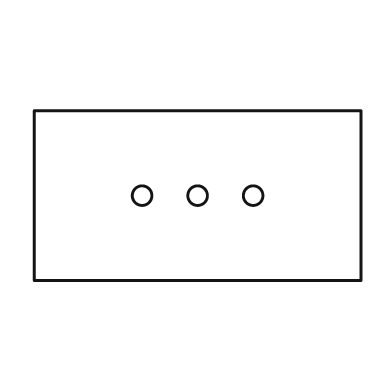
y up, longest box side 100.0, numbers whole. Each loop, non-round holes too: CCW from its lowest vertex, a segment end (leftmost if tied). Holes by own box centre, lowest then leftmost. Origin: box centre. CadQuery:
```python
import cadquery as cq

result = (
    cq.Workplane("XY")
    .moveTo(-50.0, -26.0)
    .lineTo(50.0, -26.0)
    .lineTo(50.0, 26.0)
    .lineTo(-50.0, 26.0)
    .close()
    .moveTo(-17.0, 0.0)
    .circle(3.0)
    .moveTo(0.0, 0.0)
    .circle(3.0)
    .moveTo(17.0, 0.0)
    .circle(3.0)
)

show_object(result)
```